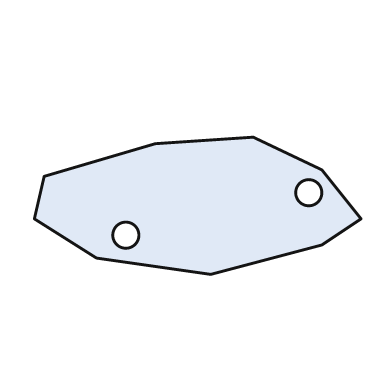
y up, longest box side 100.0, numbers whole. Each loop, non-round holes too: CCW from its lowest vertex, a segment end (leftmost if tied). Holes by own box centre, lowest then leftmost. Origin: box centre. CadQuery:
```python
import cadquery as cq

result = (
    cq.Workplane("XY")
    .moveTo(4.0, -21.0)
    .lineTo(38.0, -12.0)
    .lineTo(50.0, -4.0)
    .lineTo(38.0, 11.0)
    .lineTo(17.0, 21.0)
    .lineTo(-13.0, 19.0)
    .lineTo(-47.0, 9.0)
    .lineTo(-50.0, -4.0)
    .lineTo(-31.0, -16.0)
    .close()
    .moveTo(-22.0, -9.0)
    .circle(4.0)
    .moveTo(34.0, 4.0)
    .circle(4.0)
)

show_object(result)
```